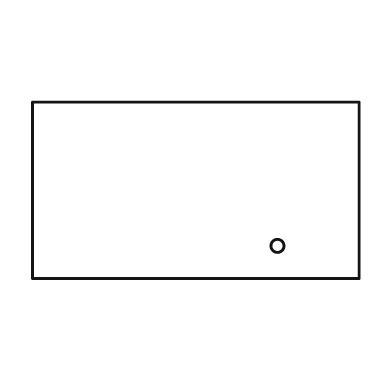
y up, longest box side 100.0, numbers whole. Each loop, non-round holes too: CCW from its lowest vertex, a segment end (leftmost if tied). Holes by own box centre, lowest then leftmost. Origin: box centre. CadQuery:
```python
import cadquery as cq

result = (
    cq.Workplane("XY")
    .moveTo(-50.0, -27.0)
    .lineTo(50.0, -27.0)
    .lineTo(50.0, 27.0)
    .lineTo(-50.0, 27.0)
    .close()
    .moveTo(25.0, -17.0)
    .circle(2.0)
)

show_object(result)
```